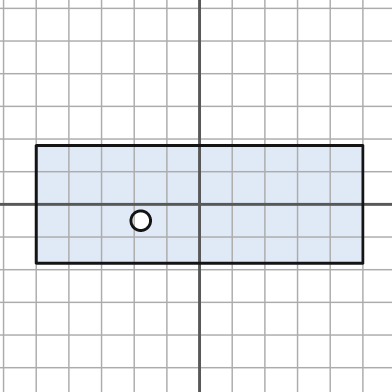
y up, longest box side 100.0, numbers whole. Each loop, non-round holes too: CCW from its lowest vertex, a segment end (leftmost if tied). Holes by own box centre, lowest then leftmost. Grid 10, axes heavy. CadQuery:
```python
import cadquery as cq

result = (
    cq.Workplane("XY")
    .moveTo(-50.0, -18.0)
    .lineTo(50.0, -18.0)
    .lineTo(50.0, 18.0)
    .lineTo(-50.0, 18.0)
    .close()
    .moveTo(-18.0, -5.0)
    .circle(3.0)
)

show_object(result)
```